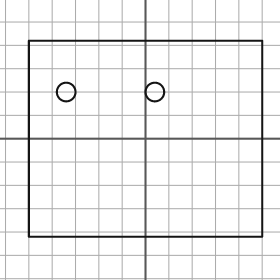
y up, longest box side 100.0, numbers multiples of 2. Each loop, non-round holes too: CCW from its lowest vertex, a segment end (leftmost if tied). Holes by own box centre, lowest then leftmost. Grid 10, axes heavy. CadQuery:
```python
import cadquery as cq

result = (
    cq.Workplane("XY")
    .moveTo(-50.0, -42.0)
    .lineTo(50.0, -42.0)
    .lineTo(50.0, 42.0)
    .lineTo(-50.0, 42.0)
    .close()
    .moveTo(-34.0, 20.0)
    .circle(4.0)
    .moveTo(4.0, 20.0)
    .circle(4.0)
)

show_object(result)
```